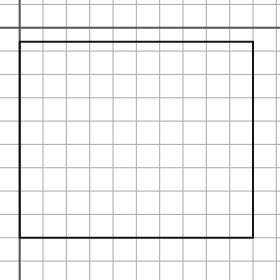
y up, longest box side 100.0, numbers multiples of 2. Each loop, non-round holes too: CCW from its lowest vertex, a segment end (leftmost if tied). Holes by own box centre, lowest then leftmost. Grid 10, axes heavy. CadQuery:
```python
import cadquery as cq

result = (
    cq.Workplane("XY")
    .moveTo(0.0, -90.0)
    .lineTo(100.0, -90.0)
    .lineTo(100.0, -6.0)
    .lineTo(0.0, -6.0)
    .close()
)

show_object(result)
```